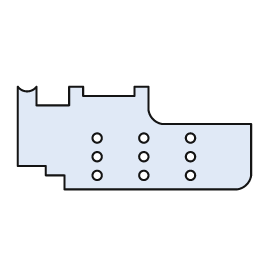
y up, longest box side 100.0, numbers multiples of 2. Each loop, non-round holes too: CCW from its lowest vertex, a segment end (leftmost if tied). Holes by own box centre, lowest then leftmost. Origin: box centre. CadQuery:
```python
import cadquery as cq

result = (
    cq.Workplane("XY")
    .moveTo(-30.0, -22.0)
    .lineTo(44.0, -22.0)
    .threePointArc((48.0, -20.0), (50.0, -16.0))
    .lineTo(50.0, 6.0)
    .lineTo(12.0, 6.0)
    .threePointArc((8.0, 8.0), (6.0, 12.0))
    .lineTo(6.0, 22.0)
    .lineTo(0.0, 22.0)
    .lineTo(0.0, 18.0)
    .lineTo(-22.0, 18.0)
    .lineTo(-22.0, 22.0)
    .lineTo(-28.0, 22.0)
    .lineTo(-28.0, 14.0)
    .lineTo(-42.0, 14.0)
    .lineTo(-42.0, 22.0)
    .threePointArc((-46.0, 20.0), (-50.0, 22.0))
    .lineTo(-50.0, -12.0)
    .lineTo(-38.0, -12.0)
    .lineTo(-38.0, -16.0)
    .lineTo(-30.0, -16.0)
    .close()
    .moveTo(-16.0, -16.0)
    .circle(2.0)
    .moveTo(4.0, -16.0)
    .circle(2.0)
    .moveTo(24.0, -16.0)
    .circle(2.0)
    .moveTo(-16.0, -8.0)
    .circle(2.0)
    .moveTo(4.0, -8.0)
    .circle(2.0)
    .moveTo(24.0, -8.0)
    .circle(2.0)
    .moveTo(-16.0, 0.0)
    .circle(2.0)
    .moveTo(4.0, 0.0)
    .circle(2.0)
    .moveTo(24.0, 0.0)
    .circle(2.0)
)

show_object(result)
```